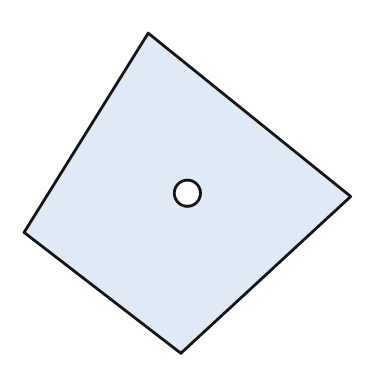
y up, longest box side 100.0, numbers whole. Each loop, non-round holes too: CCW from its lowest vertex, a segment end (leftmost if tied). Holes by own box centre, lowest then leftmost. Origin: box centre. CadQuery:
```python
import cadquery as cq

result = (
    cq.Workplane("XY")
    .moveTo(-2.0, -49.0)
    .lineTo(50.0, -1.0)
    .lineTo(-12.0, 49.0)
    .lineTo(-50.0, -12.0)
    .close()
    .moveTo(0.0, 0.0)
    .circle(4.0)
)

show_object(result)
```